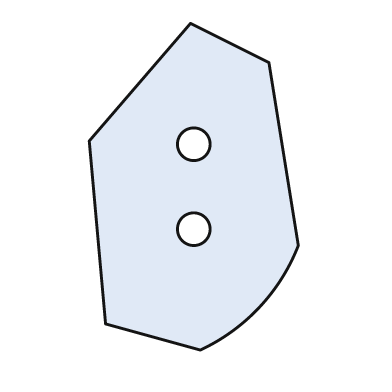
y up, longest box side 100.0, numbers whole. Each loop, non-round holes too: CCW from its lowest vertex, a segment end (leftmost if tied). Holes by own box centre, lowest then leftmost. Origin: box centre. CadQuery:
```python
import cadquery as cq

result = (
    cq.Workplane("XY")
    .moveTo(2.0, -50.0)
    .threePointArc((20.0, -37.0), (32.0, -18.0))
    .lineTo(23.0, 38.0)
    .lineTo(-1.0, 50.0)
    .lineTo(-32.0, 14.0)
    .lineTo(-27.0, -42.0)
    .close()
    .moveTo(0.0, -13.0)
    .circle(5.0)
    .moveTo(0.0, 13.0)
    .circle(5.0)
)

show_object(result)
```